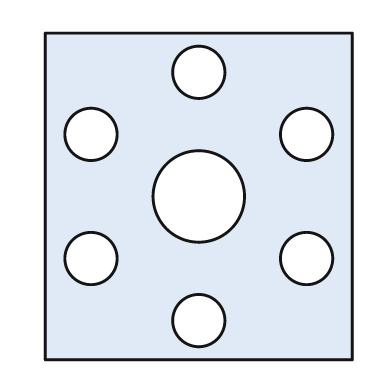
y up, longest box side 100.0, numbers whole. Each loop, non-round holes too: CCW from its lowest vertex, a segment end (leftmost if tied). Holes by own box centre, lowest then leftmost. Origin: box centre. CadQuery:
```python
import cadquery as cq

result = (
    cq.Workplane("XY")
    .moveTo(-47.0, -50.0)
    .lineTo(47.0, -50.0)
    .lineTo(47.0, 50.0)
    .lineTo(-47.0, 50.0)
    .close()
    .moveTo(0.0, -38.0)
    .circle(8.0)
    .moveTo(-33.0, -19.0)
    .circle(8.0)
    .moveTo(33.0, -19.0)
    .circle(8.0)
    .moveTo(0.0, 0.0)
    .circle(14.0)
    .moveTo(-33.0, 19.0)
    .circle(8.0)
    .moveTo(33.0, 19.0)
    .circle(8.0)
    .moveTo(0.0, 38.0)
    .circle(8.0)
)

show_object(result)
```